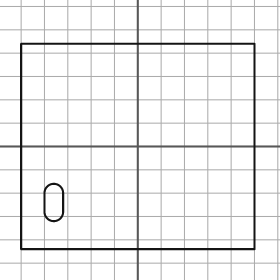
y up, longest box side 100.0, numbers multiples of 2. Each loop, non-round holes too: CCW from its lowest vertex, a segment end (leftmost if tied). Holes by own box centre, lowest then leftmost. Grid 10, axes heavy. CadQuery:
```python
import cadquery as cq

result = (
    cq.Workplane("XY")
    .moveTo(-50.0, -44.0)
    .lineTo(50.0, -44.0)
    .lineTo(50.0, 44.0)
    .lineTo(-50.0, 44.0)
    .close()
    .moveTo(-40.0, -28.0)
    .threePointArc((-36.0, -32.0), (-32.0, -28.0))
    .lineTo(-32.0, -20.0)
    .threePointArc((-36.0, -16.0), (-40.0, -20.0))
    .close()
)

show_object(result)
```